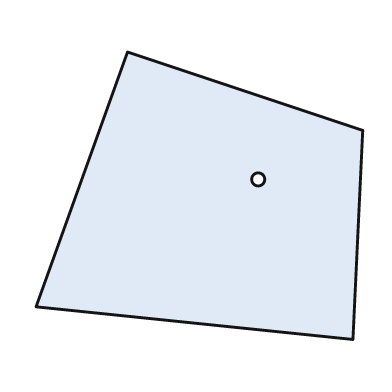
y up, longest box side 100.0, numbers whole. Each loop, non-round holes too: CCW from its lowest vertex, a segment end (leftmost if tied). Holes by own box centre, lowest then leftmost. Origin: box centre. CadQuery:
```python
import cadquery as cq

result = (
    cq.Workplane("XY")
    .moveTo(47.0, -44.0)
    .lineTo(50.0, 20.0)
    .lineTo(-22.0, 44.0)
    .lineTo(-50.0, -34.0)
    .close()
    .moveTo(18.0, 5.0)
    .circle(2.0)
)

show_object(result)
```